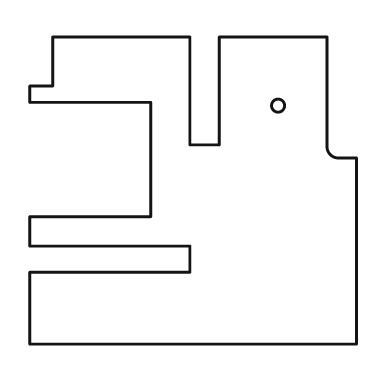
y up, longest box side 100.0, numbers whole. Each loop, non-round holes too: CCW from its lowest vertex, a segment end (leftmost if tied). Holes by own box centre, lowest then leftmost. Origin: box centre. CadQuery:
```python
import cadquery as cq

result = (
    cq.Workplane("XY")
    .moveTo(-50.0, -47.0)
    .lineTo(50.0, -47.0)
    .lineTo(50.0, 10.0)
    .lineTo(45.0, 10.0)
    .threePointArc((42.0, 11.0), (41.0, 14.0))
    .lineTo(41.0, 47.0)
    .lineTo(8.0, 47.0)
    .lineTo(8.0, 14.0)
    .lineTo(-1.0, 14.0)
    .lineTo(-1.0, 47.0)
    .lineTo(-43.0, 47.0)
    .lineTo(-43.0, 32.0)
    .lineTo(-50.0, 32.0)
    .lineTo(-50.0, 27.0)
    .lineTo(-13.0, 27.0)
    .lineTo(-13.0, -8.0)
    .lineTo(-50.0, -8.0)
    .lineTo(-50.0, -17.0)
    .lineTo(-1.0, -17.0)
    .lineTo(-1.0, -25.0)
    .lineTo(-50.0, -25.0)
    .close()
    .moveTo(26.0, 26.0)
    .circle(2.0)
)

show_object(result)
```